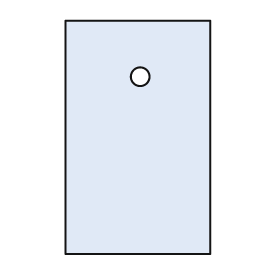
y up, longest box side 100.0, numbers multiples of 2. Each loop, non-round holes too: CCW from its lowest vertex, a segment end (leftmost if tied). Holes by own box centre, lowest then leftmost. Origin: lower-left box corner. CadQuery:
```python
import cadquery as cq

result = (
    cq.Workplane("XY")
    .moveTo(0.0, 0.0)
    .lineTo(62.0, 0.0)
    .lineTo(62.0, 100.0)
    .lineTo(0.0, 100.0)
    .close()
    .moveTo(32.0, 76.0)
    .circle(4.0)
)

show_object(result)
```